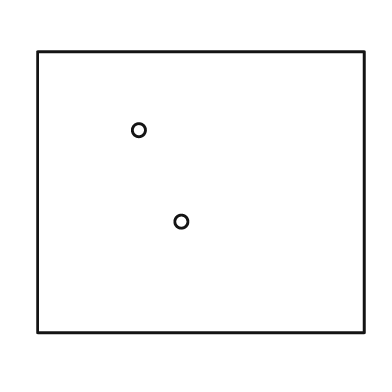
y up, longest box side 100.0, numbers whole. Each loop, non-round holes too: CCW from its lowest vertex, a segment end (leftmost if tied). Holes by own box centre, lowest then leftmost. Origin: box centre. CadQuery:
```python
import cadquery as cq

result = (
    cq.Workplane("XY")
    .moveTo(-50.0, -43.0)
    .lineTo(50.0, -43.0)
    .lineTo(50.0, 43.0)
    .lineTo(-50.0, 43.0)
    .close()
    .moveTo(-6.0, -9.0)
    .circle(2.0)
    .moveTo(-19.0, 19.0)
    .circle(2.0)
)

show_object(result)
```